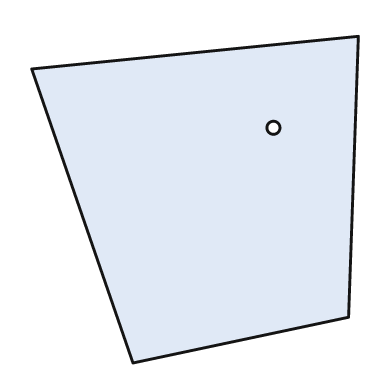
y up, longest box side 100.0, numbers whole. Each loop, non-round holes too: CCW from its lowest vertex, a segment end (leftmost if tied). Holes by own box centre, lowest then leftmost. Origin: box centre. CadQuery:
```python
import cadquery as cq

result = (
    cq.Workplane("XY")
    .moveTo(-19.0, -50.0)
    .lineTo(47.0, -36.0)
    .lineTo(50.0, 50.0)
    .lineTo(-50.0, 40.0)
    .close()
    .moveTo(24.0, 22.0)
    .circle(2.0)
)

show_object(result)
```